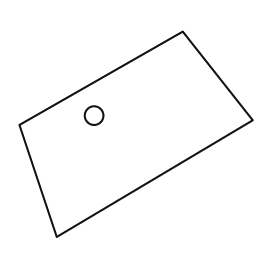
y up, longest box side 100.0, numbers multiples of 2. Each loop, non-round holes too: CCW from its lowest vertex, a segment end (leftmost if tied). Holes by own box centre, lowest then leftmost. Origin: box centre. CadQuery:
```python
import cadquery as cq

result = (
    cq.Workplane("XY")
    .moveTo(-34.0, -44.0)
    .lineTo(50.0, 6.0)
    .lineTo(20.0, 44.0)
    .lineTo(-50.0, 4.0)
    .close()
    .moveTo(-18.0, 8.0)
    .circle(4.0)
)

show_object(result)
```